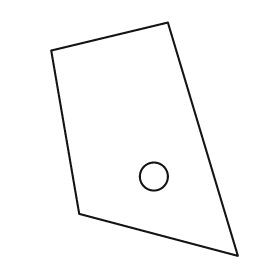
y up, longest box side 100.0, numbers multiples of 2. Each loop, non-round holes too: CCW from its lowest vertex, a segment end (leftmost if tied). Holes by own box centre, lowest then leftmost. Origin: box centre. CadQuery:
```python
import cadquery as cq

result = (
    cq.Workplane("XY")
    .moveTo(40.0, -50.0)
    .lineTo(10.0, 50.0)
    .lineTo(-40.0, 38.0)
    .lineTo(-28.0, -32.0)
    .close()
    .moveTo(4.0, -16.0)
    .circle(6.0)
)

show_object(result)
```